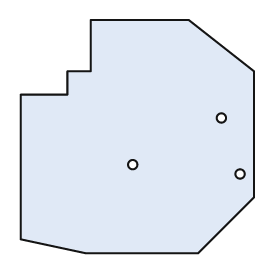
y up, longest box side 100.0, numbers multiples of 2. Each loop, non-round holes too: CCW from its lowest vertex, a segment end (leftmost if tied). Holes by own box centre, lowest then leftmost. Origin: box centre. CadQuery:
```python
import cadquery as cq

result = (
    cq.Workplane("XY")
    .moveTo(-22.0, -50.0)
    .lineTo(26.0, -50.0)
    .lineTo(50.0, -26.0)
    .lineTo(50.0, 28.0)
    .lineTo(22.0, 50.0)
    .lineTo(-20.0, 50.0)
    .lineTo(-20.0, 28.0)
    .lineTo(-30.0, 28.0)
    .lineTo(-30.0, 18.0)
    .lineTo(-50.0, 18.0)
    .lineTo(-50.0, -44.0)
    .close()
    .moveTo(44.0, -16.0)
    .circle(2.0)
    .moveTo(-2.0, -12.0)
    .circle(2.0)
    .moveTo(36.0, 8.0)
    .circle(2.0)
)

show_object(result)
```